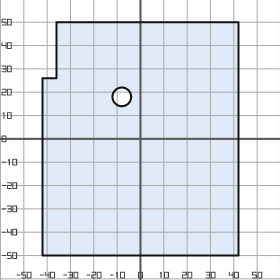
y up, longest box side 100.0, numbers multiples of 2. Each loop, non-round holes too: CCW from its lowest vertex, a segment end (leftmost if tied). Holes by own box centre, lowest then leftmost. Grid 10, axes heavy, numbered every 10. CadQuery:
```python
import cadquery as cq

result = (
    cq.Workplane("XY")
    .moveTo(-42.0, -50.0)
    .lineTo(42.0, -50.0)
    .lineTo(42.0, 50.0)
    .lineTo(-36.0, 50.0)
    .lineTo(-36.0, 26.0)
    .lineTo(-42.0, 26.0)
    .close()
    .moveTo(-8.0, 18.0)
    .circle(4.0)
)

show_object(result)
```